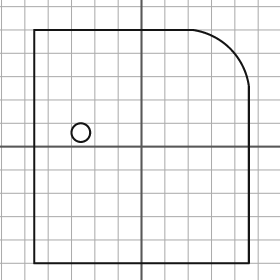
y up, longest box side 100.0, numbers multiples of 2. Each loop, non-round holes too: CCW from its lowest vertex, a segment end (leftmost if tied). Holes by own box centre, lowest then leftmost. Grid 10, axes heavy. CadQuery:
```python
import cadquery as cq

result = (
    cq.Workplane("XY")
    .moveTo(-46.0, -50.0)
    .lineTo(46.0, -50.0)
    .lineTo(46.0, 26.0)
    .threePointArc((38.0, 42.0), (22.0, 50.0))
    .lineTo(-46.0, 50.0)
    .close()
    .moveTo(-26.0, 6.0)
    .circle(4.0)
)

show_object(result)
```